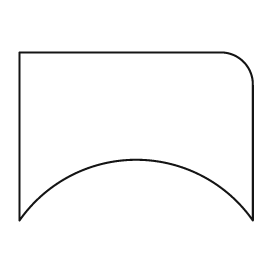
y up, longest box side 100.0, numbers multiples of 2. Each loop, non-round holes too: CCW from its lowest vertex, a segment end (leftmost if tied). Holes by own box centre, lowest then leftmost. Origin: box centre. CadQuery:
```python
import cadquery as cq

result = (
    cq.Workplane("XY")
    .moveTo(-50.0, -36.0)
    .threePointArc((0.0, -10.0), (50.0, -36.0))
    .lineTo(50.0, 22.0)
    .threePointArc((46.0, 32.0), (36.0, 36.0))
    .lineTo(-50.0, 36.0)
    .close()
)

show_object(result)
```